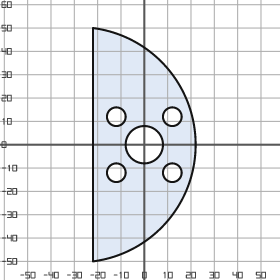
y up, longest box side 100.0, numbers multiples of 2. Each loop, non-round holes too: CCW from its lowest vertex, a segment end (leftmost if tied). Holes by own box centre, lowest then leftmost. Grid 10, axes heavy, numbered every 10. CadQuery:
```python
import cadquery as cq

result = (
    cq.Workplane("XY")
    .moveTo(-22.0, -50.0)
    .threePointArc((22.0, 0.0), (-22.0, 50.0))
    .close()
    .moveTo(-12.0, -12.0)
    .circle(4.0)
    .moveTo(12.0, -12.0)
    .circle(4.0)
    .moveTo(0.0, 0.0)
    .circle(8.0)
    .moveTo(-12.0, 12.0)
    .circle(4.0)
    .moveTo(12.0, 12.0)
    .circle(4.0)
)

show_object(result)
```